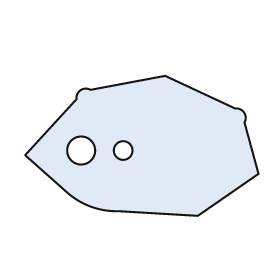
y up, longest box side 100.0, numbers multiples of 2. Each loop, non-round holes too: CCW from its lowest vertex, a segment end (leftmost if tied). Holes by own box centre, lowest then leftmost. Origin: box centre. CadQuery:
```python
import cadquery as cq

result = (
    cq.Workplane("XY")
    .moveTo(24.0, -30.0)
    .lineTo(50.0, -12.0)
    .lineTo(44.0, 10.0)
    .threePointArc((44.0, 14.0), (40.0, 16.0))
    .lineTo(10.0, 30.0)
    .lineTo(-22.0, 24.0)
    .threePointArc((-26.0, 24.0), (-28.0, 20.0))
    .lineTo(-50.0, -4.0)
    .lineTo(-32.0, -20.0)
    .threePointArc((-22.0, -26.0), (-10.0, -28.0))
    .close()
    .moveTo(-26.0, -2.0)
    .circle(6.0)
    .moveTo(-8.0, -2.0)
    .circle(4.0)
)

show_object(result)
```